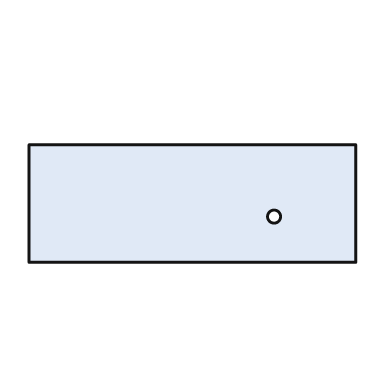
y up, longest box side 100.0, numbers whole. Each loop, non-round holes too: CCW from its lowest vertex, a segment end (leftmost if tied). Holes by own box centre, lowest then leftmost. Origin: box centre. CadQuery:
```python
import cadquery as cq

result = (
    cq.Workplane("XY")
    .moveTo(-50.0, -18.0)
    .lineTo(50.0, -18.0)
    .lineTo(50.0, 18.0)
    .lineTo(-50.0, 18.0)
    .close()
    .moveTo(25.0, -4.0)
    .circle(2.0)
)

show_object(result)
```